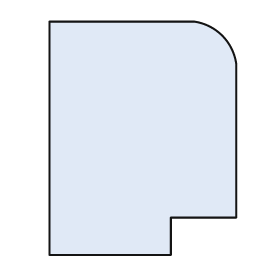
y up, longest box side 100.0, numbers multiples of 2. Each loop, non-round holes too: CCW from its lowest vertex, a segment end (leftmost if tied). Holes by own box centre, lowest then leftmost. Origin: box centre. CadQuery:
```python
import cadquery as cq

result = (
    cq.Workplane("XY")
    .moveTo(-40.0, -50.0)
    .lineTo(12.0, -50.0)
    .lineTo(12.0, -34.0)
    .lineTo(40.0, -34.0)
    .lineTo(40.0, 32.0)
    .threePointArc((34.0, 44.0), (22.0, 50.0))
    .lineTo(-40.0, 50.0)
    .close()
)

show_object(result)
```